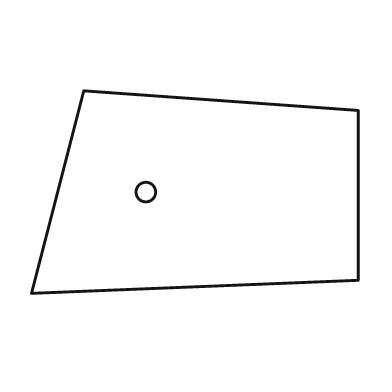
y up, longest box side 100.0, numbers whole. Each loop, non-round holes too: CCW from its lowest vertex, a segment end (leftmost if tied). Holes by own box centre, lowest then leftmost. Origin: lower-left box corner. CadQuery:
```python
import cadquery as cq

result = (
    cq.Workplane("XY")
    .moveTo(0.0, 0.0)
    .lineTo(100.0, 4.0)
    .lineTo(100.0, 56.0)
    .lineTo(16.0, 62.0)
    .close()
    .moveTo(35.0, 31.0)
    .circle(3.0)
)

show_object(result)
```